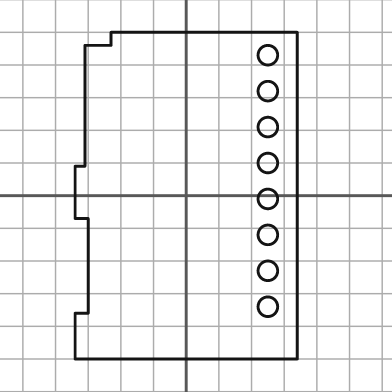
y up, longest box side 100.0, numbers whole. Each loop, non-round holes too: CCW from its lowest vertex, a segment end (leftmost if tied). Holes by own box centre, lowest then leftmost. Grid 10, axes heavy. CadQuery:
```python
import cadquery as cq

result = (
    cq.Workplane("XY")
    .moveTo(-34.0, -50.0)
    .lineTo(34.0, -50.0)
    .lineTo(34.0, 50.0)
    .lineTo(-23.0, 50.0)
    .lineTo(-23.0, 46.0)
    .lineTo(-31.0, 46.0)
    .lineTo(-31.0, 9.0)
    .lineTo(-34.0, 9.0)
    .lineTo(-34.0, -7.0)
    .lineTo(-30.0, -7.0)
    .lineTo(-30.0, -36.0)
    .lineTo(-34.0, -36.0)
    .close()
    .moveTo(25.0, -34.0)
    .circle(3.0)
    .moveTo(25.0, -23.0)
    .circle(3.0)
    .moveTo(25.0, -12.0)
    .circle(3.0)
    .moveTo(25.0, -1.0)
    .circle(3.0)
    .moveTo(25.0, 10.0)
    .circle(3.0)
    .moveTo(25.0, 21.0)
    .circle(3.0)
    .moveTo(25.0, 32.0)
    .circle(3.0)
    .moveTo(25.0, 43.0)
    .circle(3.0)
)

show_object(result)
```